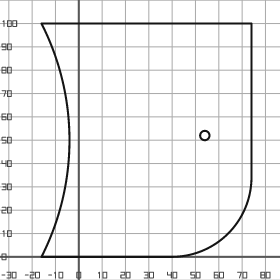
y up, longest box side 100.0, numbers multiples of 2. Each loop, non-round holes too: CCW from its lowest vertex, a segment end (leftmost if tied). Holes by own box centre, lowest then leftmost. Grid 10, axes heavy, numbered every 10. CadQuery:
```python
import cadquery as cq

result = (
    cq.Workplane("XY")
    .moveTo(-16.0, 0.0)
    .lineTo(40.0, 0.0)
    .threePointArc((64.0, 10.0), (74.0, 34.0))
    .lineTo(74.0, 100.0)
    .lineTo(-16.0, 100.0)
    .threePointArc((-4.0, 50.0), (-16.0, 0.0))
    .close()
    .moveTo(54.0, 52.0)
    .circle(2.0)
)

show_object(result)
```